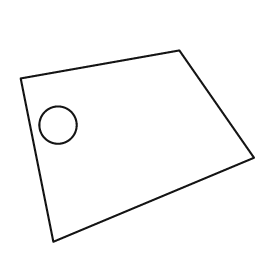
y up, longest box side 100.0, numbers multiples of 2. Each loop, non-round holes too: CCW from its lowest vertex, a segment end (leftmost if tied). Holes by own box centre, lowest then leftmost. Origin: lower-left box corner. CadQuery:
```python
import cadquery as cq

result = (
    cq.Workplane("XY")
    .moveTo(14.0, 0.0)
    .lineTo(100.0, 36.0)
    .lineTo(68.0, 82.0)
    .lineTo(0.0, 70.0)
    .close()
    .moveTo(16.0, 50.0)
    .circle(8.0)
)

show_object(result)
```